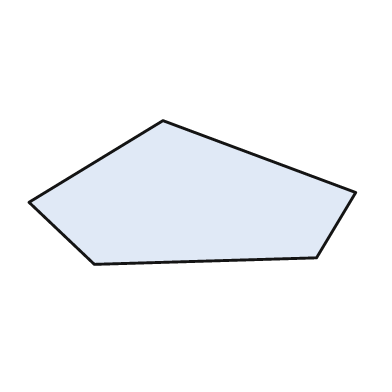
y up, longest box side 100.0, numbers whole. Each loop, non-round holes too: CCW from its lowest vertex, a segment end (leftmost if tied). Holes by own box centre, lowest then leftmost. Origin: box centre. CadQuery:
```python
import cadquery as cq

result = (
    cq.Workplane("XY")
    .moveTo(-30.0, -22.0)
    .lineTo(38.0, -20.0)
    .lineTo(50.0, 0.0)
    .lineTo(-9.0, 22.0)
    .lineTo(-50.0, -3.0)
    .close()
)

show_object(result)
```